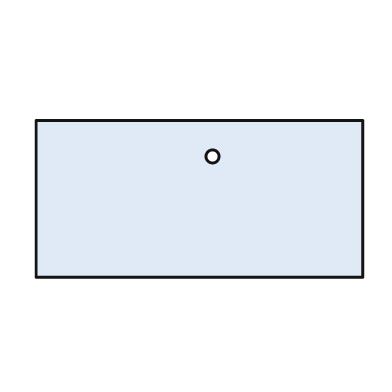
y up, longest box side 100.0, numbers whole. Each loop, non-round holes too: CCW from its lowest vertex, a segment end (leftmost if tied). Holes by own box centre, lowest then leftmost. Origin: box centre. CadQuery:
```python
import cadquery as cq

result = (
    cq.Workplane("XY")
    .moveTo(-50.0, -24.0)
    .lineTo(50.0, -24.0)
    .lineTo(50.0, 24.0)
    .lineTo(-50.0, 24.0)
    .close()
    .moveTo(4.0, 13.0)
    .circle(2.0)
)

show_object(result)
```